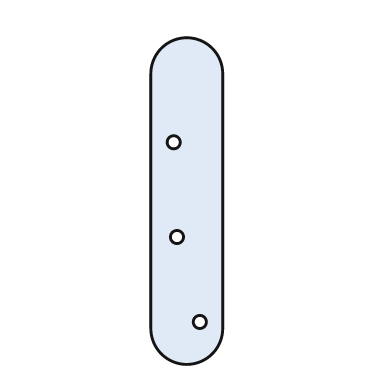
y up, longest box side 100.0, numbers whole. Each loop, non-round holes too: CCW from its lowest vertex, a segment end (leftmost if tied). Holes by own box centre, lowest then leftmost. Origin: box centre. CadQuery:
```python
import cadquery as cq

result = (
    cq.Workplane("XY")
    .moveTo(-11.0, -39.0)
    .threePointArc((0.0, -50.0), (11.0, -39.0))
    .lineTo(11.0, 39.0)
    .threePointArc((0.0, 50.0), (-11.0, 39.0))
    .close()
    .moveTo(4.0, -37.0)
    .circle(2.0)
    .moveTo(-3.0, -11.0)
    .circle(2.0)
    .moveTo(-4.0, 18.0)
    .circle(2.0)
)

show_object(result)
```